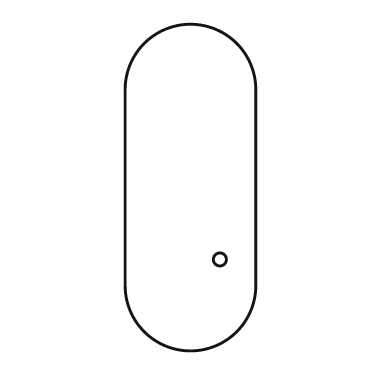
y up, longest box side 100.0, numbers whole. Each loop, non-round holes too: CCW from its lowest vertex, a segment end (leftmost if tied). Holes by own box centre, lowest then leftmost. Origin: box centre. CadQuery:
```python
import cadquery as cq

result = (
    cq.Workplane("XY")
    .moveTo(-20.0, -30.0)
    .threePointArc((0.0, -50.0), (20.0, -30.0))
    .lineTo(20.0, 30.0)
    .threePointArc((0.0, 50.0), (-20.0, 30.0))
    .close()
    .moveTo(9.0, -22.0)
    .circle(2.0)
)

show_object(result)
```